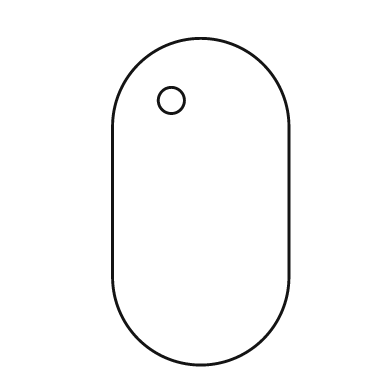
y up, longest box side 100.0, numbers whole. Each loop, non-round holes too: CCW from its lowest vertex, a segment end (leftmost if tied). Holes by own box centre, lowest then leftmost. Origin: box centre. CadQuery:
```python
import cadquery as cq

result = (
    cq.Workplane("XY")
    .moveTo(-27.0, -23.0)
    .threePointArc((0.0, -50.0), (27.0, -23.0))
    .lineTo(27.0, 23.0)
    .threePointArc((0.0, 50.0), (-27.0, 23.0))
    .close()
    .moveTo(-9.0, 31.0)
    .circle(4.0)
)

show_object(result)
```